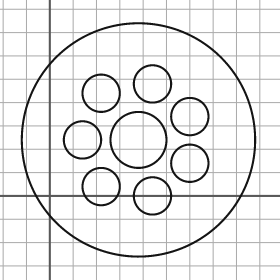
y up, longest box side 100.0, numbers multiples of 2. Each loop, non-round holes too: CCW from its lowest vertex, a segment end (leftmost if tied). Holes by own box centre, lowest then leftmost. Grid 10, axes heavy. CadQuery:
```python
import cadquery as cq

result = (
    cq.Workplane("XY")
    .moveTo(38.0, 24.0)
    .circle(50.0)
    .moveTo(44.0, 0.0)
    .circle(8.0)
    .moveTo(22.0, 4.0)
    .circle(8.0)
    .moveTo(60.0, 14.0)
    .circle(8.0)
    .moveTo(14.0, 24.0)
    .circle(8.0)
    .moveTo(38.0, 24.0)
    .circle(12.0)
    .moveTo(60.0, 34.0)
    .circle(8.0)
    .moveTo(22.0, 44.0)
    .circle(8.0)
    .moveTo(44.0, 48.0)
    .circle(8.0)
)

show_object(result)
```